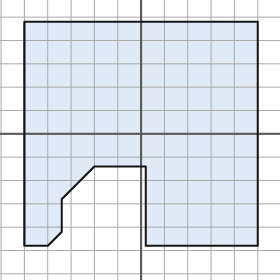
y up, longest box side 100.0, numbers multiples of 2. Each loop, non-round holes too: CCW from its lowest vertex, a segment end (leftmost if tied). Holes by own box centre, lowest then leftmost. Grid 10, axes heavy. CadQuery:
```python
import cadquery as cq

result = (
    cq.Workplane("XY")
    .moveTo(-50.0, -48.0)
    .lineTo(-40.0, -48.0)
    .lineTo(-34.0, -42.0)
    .lineTo(-34.0, -28.0)
    .lineTo(-20.0, -14.0)
    .lineTo(2.0, -14.0)
    .lineTo(2.0, -48.0)
    .lineTo(50.0, -48.0)
    .lineTo(50.0, 48.0)
    .lineTo(-50.0, 48.0)
    .close()
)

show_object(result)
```